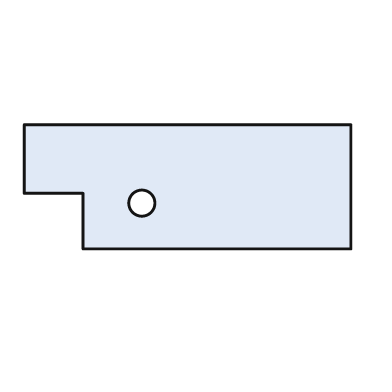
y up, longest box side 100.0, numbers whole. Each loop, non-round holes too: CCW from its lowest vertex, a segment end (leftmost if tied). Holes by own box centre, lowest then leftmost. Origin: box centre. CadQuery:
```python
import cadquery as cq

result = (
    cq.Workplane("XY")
    .moveTo(-32.0, -19.0)
    .lineTo(50.0, -19.0)
    .lineTo(50.0, 19.0)
    .lineTo(-50.0, 19.0)
    .lineTo(-50.0, -2.0)
    .lineTo(-32.0, -2.0)
    .close()
    .moveTo(-14.0, -5.0)
    .circle(4.0)
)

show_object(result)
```